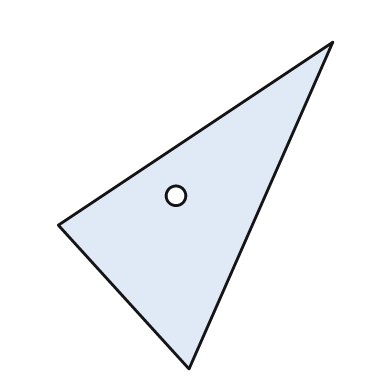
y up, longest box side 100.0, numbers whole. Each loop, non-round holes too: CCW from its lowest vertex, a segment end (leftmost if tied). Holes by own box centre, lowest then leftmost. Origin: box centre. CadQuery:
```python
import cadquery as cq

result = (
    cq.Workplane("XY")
    .moveTo(-2.0, -50.0)
    .lineTo(42.0, 50.0)
    .lineTo(-42.0, -6.0)
    .close()
    .moveTo(-6.0, 3.0)
    .circle(3.0)
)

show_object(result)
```